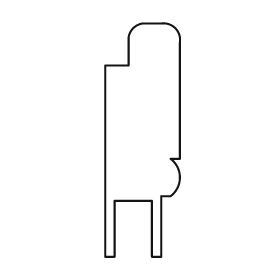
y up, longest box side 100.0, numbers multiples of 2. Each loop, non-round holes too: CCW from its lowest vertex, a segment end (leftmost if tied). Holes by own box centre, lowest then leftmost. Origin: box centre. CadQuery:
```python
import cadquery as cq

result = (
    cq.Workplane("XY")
    .moveTo(-16.0, -50.0)
    .lineTo(-12.0, -50.0)
    .lineTo(-12.0, -26.0)
    .lineTo(4.0, -26.0)
    .lineTo(4.0, -50.0)
    .lineTo(8.0, -50.0)
    .lineTo(8.0, -24.0)
    .lineTo(12.0, -24.0)
    .threePointArc((16.0, -16.0), (12.0, -8.0))
    .lineTo(16.0, -8.0)
    .lineTo(16.0, 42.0)
    .threePointArc((14.0, 48.0), (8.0, 50.0))
    .lineTo(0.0, 50.0)
    .threePointArc((-4.0, 48.0), (-6.0, 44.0))
    .lineTo(-6.0, 32.0)
    .lineTo(-16.0, 32.0)
    .close()
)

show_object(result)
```